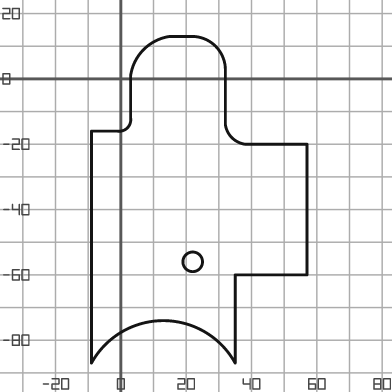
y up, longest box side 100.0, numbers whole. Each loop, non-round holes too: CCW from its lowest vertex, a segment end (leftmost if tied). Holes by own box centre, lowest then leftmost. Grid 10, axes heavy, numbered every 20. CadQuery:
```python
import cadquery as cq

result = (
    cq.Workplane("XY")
    .moveTo(-9.0, -87.0)
    .threePointArc((13.0, -74.0), (35.0, -87.0))
    .lineTo(35.0, -60.0)
    .lineTo(57.0, -60.0)
    .lineTo(57.0, -20.0)
    .lineTo(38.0, -20.0)
    .threePointArc((34.0, -18.0), (32.0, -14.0))
    .lineTo(32.0, 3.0)
    .threePointArc((29.0, 10.0), (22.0, 13.0))
    .lineTo(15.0, 13.0)
    .threePointArc((7.0, 9.0), (3.0, 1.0))
    .lineTo(3.0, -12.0)
    .threePointArc((2.0, -15.0), (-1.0, -16.0))
    .lineTo(-9.0, -16.0)
    .close()
    .moveTo(22.0, -56.0)
    .circle(3.0)
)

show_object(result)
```